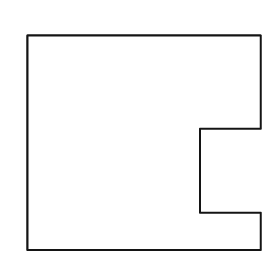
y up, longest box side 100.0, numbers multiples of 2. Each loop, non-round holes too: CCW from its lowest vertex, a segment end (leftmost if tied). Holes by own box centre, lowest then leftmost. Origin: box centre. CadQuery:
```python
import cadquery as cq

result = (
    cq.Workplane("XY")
    .moveTo(-50.0, -46.0)
    .lineTo(50.0, -46.0)
    .lineTo(50.0, -30.0)
    .lineTo(24.0, -30.0)
    .lineTo(24.0, 6.0)
    .lineTo(50.0, 6.0)
    .lineTo(50.0, 46.0)
    .lineTo(-50.0, 46.0)
    .close()
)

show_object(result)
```